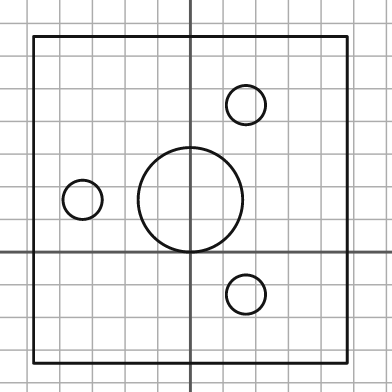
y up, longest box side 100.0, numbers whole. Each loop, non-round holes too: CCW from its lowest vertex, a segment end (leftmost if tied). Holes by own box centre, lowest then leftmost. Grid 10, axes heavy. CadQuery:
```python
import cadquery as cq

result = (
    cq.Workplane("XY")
    .moveTo(-48.0, -34.0)
    .lineTo(48.0, -34.0)
    .lineTo(48.0, 66.0)
    .lineTo(-48.0, 66.0)
    .close()
    .moveTo(17.0, -13.0)
    .circle(6.0)
    .moveTo(-33.0, 16.0)
    .circle(6.0)
    .moveTo(0.0, 16.0)
    .circle(16.0)
    .moveTo(17.0, 45.0)
    .circle(6.0)
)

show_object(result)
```